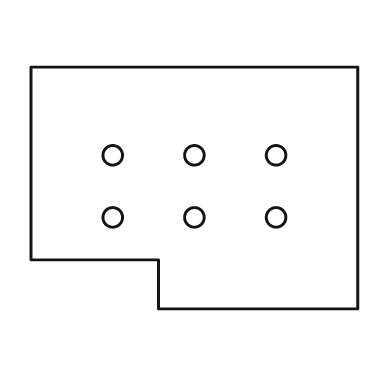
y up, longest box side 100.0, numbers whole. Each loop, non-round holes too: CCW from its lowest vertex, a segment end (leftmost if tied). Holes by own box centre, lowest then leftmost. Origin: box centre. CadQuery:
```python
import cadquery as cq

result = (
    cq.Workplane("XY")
    .moveTo(-11.0, -37.0)
    .lineTo(50.0, -37.0)
    .lineTo(50.0, 37.0)
    .lineTo(-50.0, 37.0)
    .lineTo(-50.0, -22.0)
    .lineTo(-11.0, -22.0)
    .close()
    .moveTo(-25.0, -9.0)
    .circle(3.0)
    .moveTo(0.0, -9.0)
    .circle(3.0)
    .moveTo(25.0, -9.0)
    .circle(3.0)
    .moveTo(-25.0, 10.0)
    .circle(3.0)
    .moveTo(0.0, 10.0)
    .circle(3.0)
    .moveTo(25.0, 10.0)
    .circle(3.0)
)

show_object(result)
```